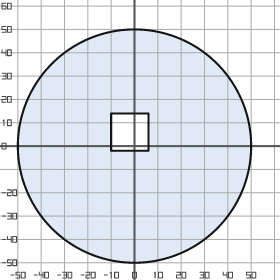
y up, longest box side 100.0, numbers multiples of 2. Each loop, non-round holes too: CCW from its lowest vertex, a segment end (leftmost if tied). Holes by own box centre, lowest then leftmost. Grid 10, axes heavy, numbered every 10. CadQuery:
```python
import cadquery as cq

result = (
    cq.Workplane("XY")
    .moveTo(0.0, 0.0)
    .circle(50.0)
    .moveTo(-10.0, -2.0)
    .lineTo(6.0, -2.0)
    .lineTo(6.0, 14.0)
    .lineTo(-10.0, 14.0)
    .close()
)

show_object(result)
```